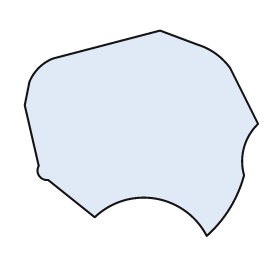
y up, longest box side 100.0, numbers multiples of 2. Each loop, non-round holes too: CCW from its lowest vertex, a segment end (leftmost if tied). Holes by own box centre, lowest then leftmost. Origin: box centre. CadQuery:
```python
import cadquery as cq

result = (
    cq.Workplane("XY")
    .moveTo(28.0, -44.0)
    .threePointArc((38.0, -32.0), (44.0, -18.0))
    .threePointArc((44.0, -6.0), (50.0, 4.0))
    .lineTo(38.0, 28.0)
    .threePointArc((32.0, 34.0), (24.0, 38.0))
    .lineTo(8.0, 44.0)
    .lineTo(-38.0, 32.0)
    .threePointArc((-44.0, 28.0), (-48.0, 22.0))
    .lineTo(-50.0, 12.0)
    .lineTo(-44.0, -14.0)
    .threePointArc((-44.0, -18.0), (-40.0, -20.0))
    .lineTo(-20.0, -36.0)
    .threePointArc((6.0, -28.0), (28.0, -44.0))
    .close()
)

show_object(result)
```